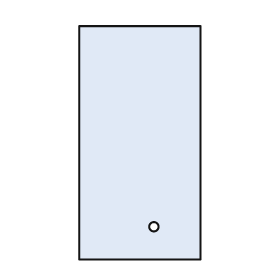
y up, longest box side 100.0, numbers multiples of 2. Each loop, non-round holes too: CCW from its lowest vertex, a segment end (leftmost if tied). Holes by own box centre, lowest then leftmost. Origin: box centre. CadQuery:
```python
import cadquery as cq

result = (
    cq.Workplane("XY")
    .moveTo(-26.0, -50.0)
    .lineTo(26.0, -50.0)
    .lineTo(26.0, 50.0)
    .lineTo(-26.0, 50.0)
    .close()
    .moveTo(6.0, -36.0)
    .circle(2.0)
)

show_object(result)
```